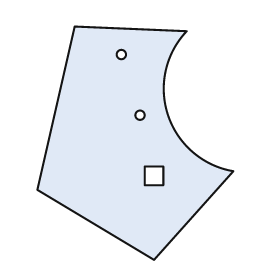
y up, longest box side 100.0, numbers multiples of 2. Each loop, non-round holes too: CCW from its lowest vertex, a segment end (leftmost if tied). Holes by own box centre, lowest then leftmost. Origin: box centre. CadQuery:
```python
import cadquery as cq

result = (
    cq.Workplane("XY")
    .moveTo(8.0, -50.0)
    .lineTo(42.0, -12.0)
    .threePointArc((14.0, 12.0), (22.0, 48.0))
    .lineTo(-26.0, 50.0)
    .lineTo(-42.0, -20.0)
    .close()
    .moveTo(4.0, -18.0)
    .lineTo(12.0, -18.0)
    .lineTo(12.0, -10.0)
    .lineTo(4.0, -10.0)
    .close()
    .moveTo(2.0, 12.0)
    .circle(2.0)
    .moveTo(-6.0, 38.0)
    .circle(2.0)
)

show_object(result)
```